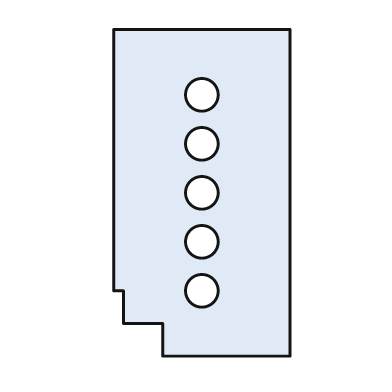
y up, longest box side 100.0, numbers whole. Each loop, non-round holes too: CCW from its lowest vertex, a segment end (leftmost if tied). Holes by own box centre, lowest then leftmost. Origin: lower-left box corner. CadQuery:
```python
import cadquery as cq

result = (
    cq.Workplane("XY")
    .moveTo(15.0, 0.0)
    .lineTo(54.0, 0.0)
    .lineTo(54.0, 100.0)
    .lineTo(0.0, 100.0)
    .lineTo(0.0, 20.0)
    .lineTo(3.0, 20.0)
    .lineTo(3.0, 10.0)
    .lineTo(15.0, 10.0)
    .close()
    .moveTo(27.0, 20.0)
    .circle(5.0)
    .moveTo(27.0, 35.0)
    .circle(5.0)
    .moveTo(27.0, 50.0)
    .circle(5.0)
    .moveTo(27.0, 65.0)
    .circle(5.0)
    .moveTo(27.0, 80.0)
    .circle(5.0)
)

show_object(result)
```